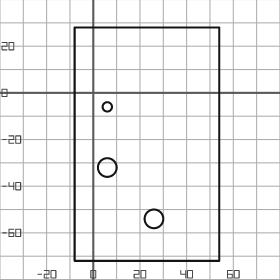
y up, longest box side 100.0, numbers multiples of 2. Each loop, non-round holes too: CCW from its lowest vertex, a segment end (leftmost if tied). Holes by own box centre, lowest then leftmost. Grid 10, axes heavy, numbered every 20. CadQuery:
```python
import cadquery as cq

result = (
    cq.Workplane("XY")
    .moveTo(-8.0, -72.0)
    .lineTo(54.0, -72.0)
    .lineTo(54.0, 28.0)
    .lineTo(-8.0, 28.0)
    .close()
    .moveTo(26.0, -54.0)
    .circle(4.0)
    .moveTo(6.0, -32.0)
    .circle(4.0)
    .moveTo(6.0, -6.0)
    .circle(2.0)
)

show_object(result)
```